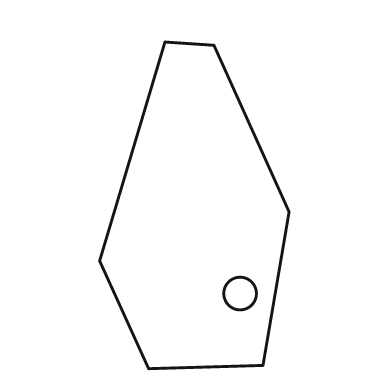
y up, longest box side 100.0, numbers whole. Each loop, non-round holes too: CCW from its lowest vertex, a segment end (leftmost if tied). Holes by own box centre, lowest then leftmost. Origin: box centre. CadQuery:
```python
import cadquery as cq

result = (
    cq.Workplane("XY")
    .moveTo(-14.0, -50.0)
    .lineTo(21.0, -49.0)
    .lineTo(29.0, -2.0)
    .lineTo(6.0, 49.0)
    .lineTo(-9.0, 50.0)
    .lineTo(-29.0, -17.0)
    .close()
    .moveTo(14.0, -27.0)
    .circle(5.0)
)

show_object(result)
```